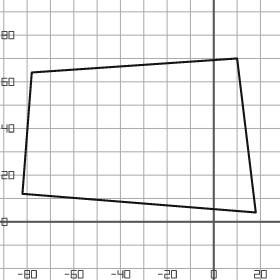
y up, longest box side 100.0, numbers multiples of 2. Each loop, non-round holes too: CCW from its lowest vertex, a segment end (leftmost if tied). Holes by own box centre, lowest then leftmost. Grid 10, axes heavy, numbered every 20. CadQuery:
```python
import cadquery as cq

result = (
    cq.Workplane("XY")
    .moveTo(18.0, 4.0)
    .lineTo(10.0, 70.0)
    .lineTo(-78.0, 64.0)
    .lineTo(-82.0, 12.0)
    .close()
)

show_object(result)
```